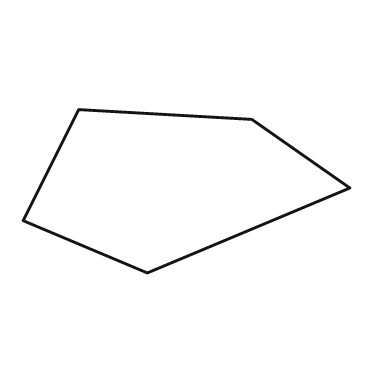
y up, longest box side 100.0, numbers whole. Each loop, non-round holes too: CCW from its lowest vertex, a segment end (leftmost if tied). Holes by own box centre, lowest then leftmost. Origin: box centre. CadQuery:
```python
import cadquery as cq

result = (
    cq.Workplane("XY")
    .moveTo(-12.0, -25.0)
    .lineTo(50.0, 1.0)
    .lineTo(20.0, 22.0)
    .lineTo(-33.0, 25.0)
    .lineTo(-50.0, -9.0)
    .close()
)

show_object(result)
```